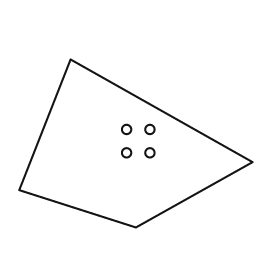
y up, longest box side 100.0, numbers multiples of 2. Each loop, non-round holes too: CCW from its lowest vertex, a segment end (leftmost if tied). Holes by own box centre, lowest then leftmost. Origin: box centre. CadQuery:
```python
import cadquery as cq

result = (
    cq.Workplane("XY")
    .moveTo(0.0, -36.0)
    .lineTo(50.0, -8.0)
    .lineTo(-28.0, 36.0)
    .lineTo(-50.0, -20.0)
    .close()
    .moveTo(-4.0, -4.0)
    .circle(2.0)
    .moveTo(6.0, -4.0)
    .circle(2.0)
    .moveTo(-4.0, 6.0)
    .circle(2.0)
    .moveTo(6.0, 6.0)
    .circle(2.0)
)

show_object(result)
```